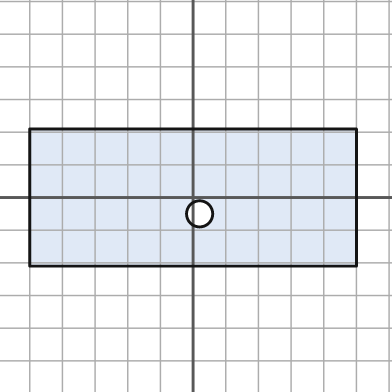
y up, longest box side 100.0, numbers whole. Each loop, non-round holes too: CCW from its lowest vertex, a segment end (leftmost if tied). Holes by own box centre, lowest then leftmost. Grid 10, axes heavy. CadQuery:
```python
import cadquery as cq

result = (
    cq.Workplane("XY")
    .moveTo(-50.0, -21.0)
    .lineTo(50.0, -21.0)
    .lineTo(50.0, 21.0)
    .lineTo(-50.0, 21.0)
    .close()
    .moveTo(2.0, -5.0)
    .circle(4.0)
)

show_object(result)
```